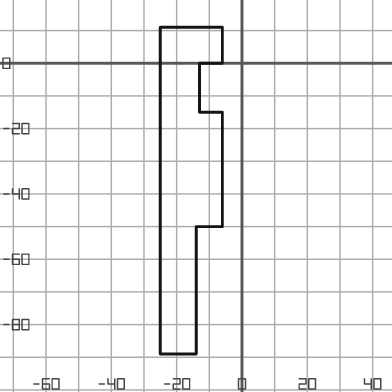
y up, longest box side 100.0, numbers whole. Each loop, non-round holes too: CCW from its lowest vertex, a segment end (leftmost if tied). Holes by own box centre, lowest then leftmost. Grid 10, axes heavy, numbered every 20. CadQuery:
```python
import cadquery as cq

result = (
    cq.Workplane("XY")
    .moveTo(-25.0, -89.0)
    .lineTo(-14.0, -89.0)
    .lineTo(-14.0, -50.0)
    .lineTo(-6.0, -50.0)
    .lineTo(-6.0, -15.0)
    .lineTo(-13.0, -15.0)
    .lineTo(-13.0, 0.0)
    .lineTo(-6.0, 0.0)
    .lineTo(-6.0, 11.0)
    .lineTo(-25.0, 11.0)
    .close()
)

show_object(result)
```